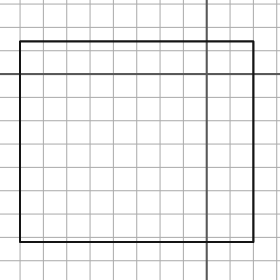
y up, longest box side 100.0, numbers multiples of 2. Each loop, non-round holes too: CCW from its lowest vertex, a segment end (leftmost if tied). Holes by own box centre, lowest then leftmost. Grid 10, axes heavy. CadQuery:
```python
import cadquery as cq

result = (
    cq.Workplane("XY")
    .moveTo(-80.0, -72.0)
    .lineTo(20.0, -72.0)
    .lineTo(20.0, 14.0)
    .lineTo(-80.0, 14.0)
    .close()
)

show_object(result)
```